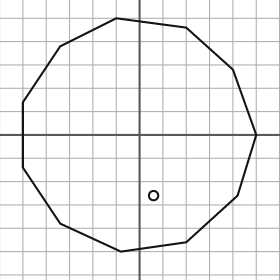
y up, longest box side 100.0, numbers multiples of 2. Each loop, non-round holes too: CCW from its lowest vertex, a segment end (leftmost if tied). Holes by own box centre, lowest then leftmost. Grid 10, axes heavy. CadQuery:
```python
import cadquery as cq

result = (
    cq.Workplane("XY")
    .moveTo(-8.0, -50.0)
    .lineTo(20.0, -46.0)
    .lineTo(42.0, -26.0)
    .lineTo(50.0, 0.0)
    .lineTo(40.0, 28.0)
    .lineTo(20.0, 46.0)
    .lineTo(-10.0, 50.0)
    .lineTo(-34.0, 38.0)
    .lineTo(-50.0, 14.0)
    .lineTo(-50.0, -14.0)
    .lineTo(-34.0, -38.0)
    .close()
    .moveTo(6.0, -26.0)
    .circle(2.0)
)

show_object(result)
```